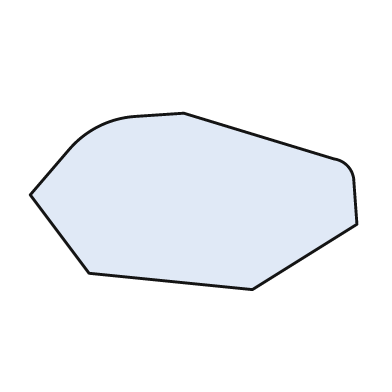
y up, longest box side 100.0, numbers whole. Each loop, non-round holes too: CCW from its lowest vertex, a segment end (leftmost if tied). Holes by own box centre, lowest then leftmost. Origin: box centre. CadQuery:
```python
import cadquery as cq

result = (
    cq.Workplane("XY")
    .moveTo(18.0, -27.0)
    .lineTo(50.0, -7.0)
    .lineTo(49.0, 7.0)
    .threePointArc((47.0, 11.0), (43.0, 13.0))
    .lineTo(-3.0, 27.0)
    .lineTo(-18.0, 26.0)
    .threePointArc((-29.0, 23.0), (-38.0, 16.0))
    .lineTo(-50.0, 2.0)
    .lineTo(-32.0, -22.0)
    .close()
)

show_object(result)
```